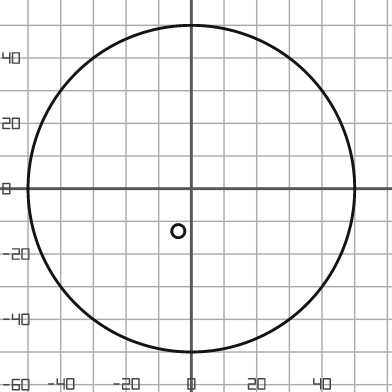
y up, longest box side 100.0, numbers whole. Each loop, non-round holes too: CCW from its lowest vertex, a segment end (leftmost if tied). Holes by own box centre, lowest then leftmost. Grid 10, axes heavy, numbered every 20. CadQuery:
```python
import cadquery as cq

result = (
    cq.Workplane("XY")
    .moveTo(0.0, 0.0)
    .circle(50.0)
    .moveTo(-4.0, -13.0)
    .circle(2.0)
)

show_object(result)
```